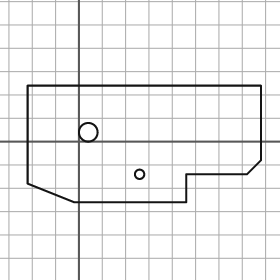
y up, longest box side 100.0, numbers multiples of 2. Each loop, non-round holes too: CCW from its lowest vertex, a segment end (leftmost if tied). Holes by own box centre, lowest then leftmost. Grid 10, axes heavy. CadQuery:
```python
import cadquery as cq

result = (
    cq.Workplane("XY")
    .moveTo(-2.0, -26.0)
    .lineTo(46.0, -26.0)
    .lineTo(46.0, -14.0)
    .lineTo(72.0, -14.0)
    .lineTo(78.0, -8.0)
    .lineTo(78.0, 24.0)
    .lineTo(-22.0, 24.0)
    .lineTo(-22.0, -18.0)
    .close()
    .moveTo(26.0, -14.0)
    .circle(2.0)
    .moveTo(4.0, 4.0)
    .circle(4.0)
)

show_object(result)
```